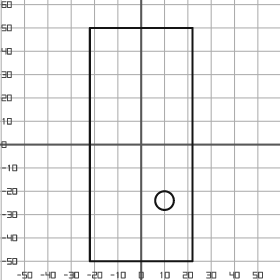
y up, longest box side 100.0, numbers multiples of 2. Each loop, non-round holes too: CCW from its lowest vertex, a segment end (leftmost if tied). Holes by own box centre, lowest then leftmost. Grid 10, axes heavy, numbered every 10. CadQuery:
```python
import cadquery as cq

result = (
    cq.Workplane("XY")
    .moveTo(-22.0, -50.0)
    .lineTo(22.0, -50.0)
    .lineTo(22.0, 50.0)
    .lineTo(-22.0, 50.0)
    .close()
    .moveTo(10.0, -24.0)
    .circle(4.0)
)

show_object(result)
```